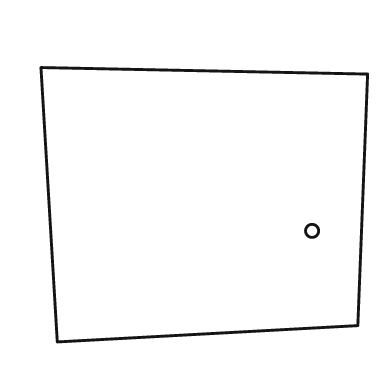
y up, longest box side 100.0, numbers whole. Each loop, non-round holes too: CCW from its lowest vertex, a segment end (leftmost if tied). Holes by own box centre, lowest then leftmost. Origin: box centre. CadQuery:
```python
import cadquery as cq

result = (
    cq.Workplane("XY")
    .moveTo(-45.0, -42.0)
    .lineTo(47.0, -37.0)
    .lineTo(50.0, 40.0)
    .lineTo(-50.0, 42.0)
    .close()
    .moveTo(33.0, -8.0)
    .circle(2.0)
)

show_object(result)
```